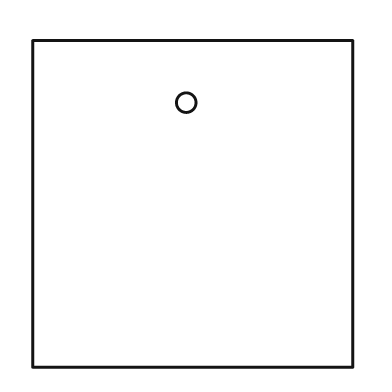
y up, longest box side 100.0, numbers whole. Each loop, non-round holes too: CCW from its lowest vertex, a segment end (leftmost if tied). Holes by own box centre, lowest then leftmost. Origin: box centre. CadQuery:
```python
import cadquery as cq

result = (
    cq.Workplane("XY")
    .moveTo(-49.0, -50.0)
    .lineTo(49.0, -50.0)
    .lineTo(49.0, 50.0)
    .lineTo(-49.0, 50.0)
    .close()
    .moveTo(-2.0, 31.0)
    .circle(3.0)
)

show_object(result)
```